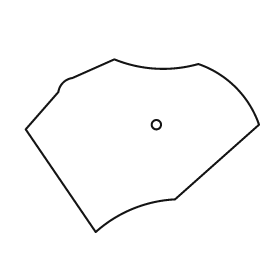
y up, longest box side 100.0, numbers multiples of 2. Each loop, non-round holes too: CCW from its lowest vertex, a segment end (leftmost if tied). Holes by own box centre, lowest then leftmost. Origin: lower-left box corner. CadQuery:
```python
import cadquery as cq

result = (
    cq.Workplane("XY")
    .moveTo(30.0, 0.0)
    .threePointArc((46.0, 10.0), (64.0, 14.0))
    .lineTo(100.0, 46.0)
    .threePointArc((90.0, 62.0), (74.0, 72.0))
    .threePointArc((56.0, 70.0), (38.0, 74.0))
    .lineTo(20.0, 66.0)
    .threePointArc((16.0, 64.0), (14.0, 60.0))
    .lineTo(0.0, 44.0)
    .close()
    .moveTo(56.0, 46.0)
    .circle(2.0)
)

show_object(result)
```